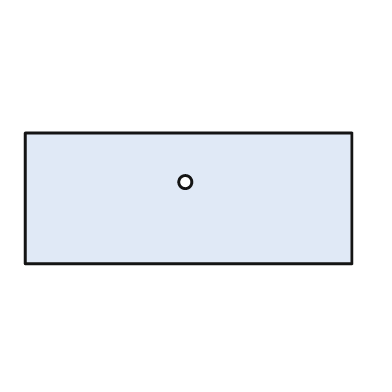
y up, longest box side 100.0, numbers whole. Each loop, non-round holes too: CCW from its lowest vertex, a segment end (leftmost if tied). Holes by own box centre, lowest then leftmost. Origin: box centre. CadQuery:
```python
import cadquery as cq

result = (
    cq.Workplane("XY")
    .moveTo(-50.0, -20.0)
    .lineTo(50.0, -20.0)
    .lineTo(50.0, 20.0)
    .lineTo(-50.0, 20.0)
    .close()
    .moveTo(-1.0, 5.0)
    .circle(2.0)
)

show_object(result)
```